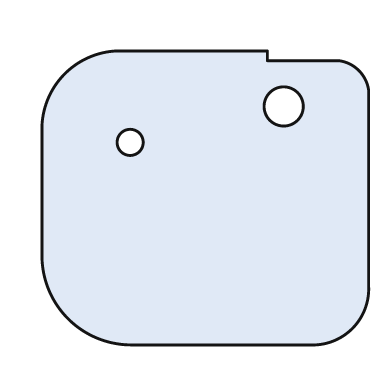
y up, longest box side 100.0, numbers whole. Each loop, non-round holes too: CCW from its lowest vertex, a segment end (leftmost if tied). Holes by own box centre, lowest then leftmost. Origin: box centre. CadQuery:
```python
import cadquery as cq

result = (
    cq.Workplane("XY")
    .moveTo(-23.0, -45.0)
    .lineTo(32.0, -45.0)
    .threePointArc((45.0, -40.0), (50.0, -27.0))
    .lineTo(50.0, 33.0)
    .threePointArc((47.0, 39.0), (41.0, 42.0))
    .lineTo(19.0, 42.0)
    .lineTo(19.0, 45.0)
    .lineTo(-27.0, 45.0)
    .threePointArc((-43.0, 38.0), (-50.0, 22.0))
    .lineTo(-50.0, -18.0)
    .threePointArc((-42.0, -37.0), (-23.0, -45.0))
    .close()
    .moveTo(-23.0, 17.0)
    .circle(4.0)
    .moveTo(24.0, 28.0)
    .circle(6.0)
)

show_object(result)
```